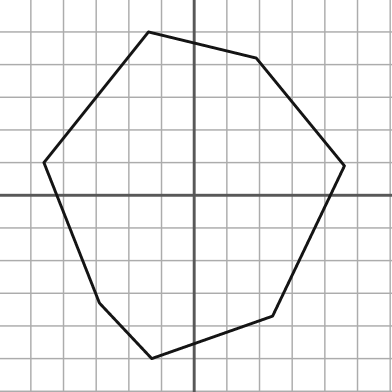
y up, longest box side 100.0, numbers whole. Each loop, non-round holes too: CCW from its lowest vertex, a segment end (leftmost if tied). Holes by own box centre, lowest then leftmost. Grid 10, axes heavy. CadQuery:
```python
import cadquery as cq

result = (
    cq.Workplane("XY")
    .moveTo(-13.0, -50.0)
    .lineTo(24.0, -37.0)
    .lineTo(46.0, 9.0)
    .lineTo(19.0, 42.0)
    .lineTo(-14.0, 50.0)
    .lineTo(-46.0, 10.0)
    .lineTo(-29.0, -33.0)
    .close()
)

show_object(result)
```